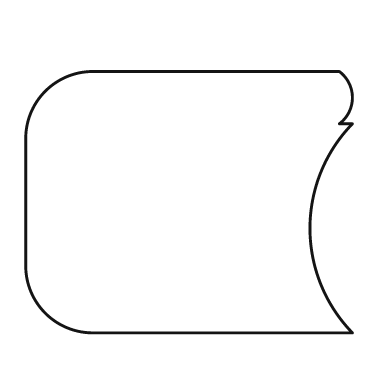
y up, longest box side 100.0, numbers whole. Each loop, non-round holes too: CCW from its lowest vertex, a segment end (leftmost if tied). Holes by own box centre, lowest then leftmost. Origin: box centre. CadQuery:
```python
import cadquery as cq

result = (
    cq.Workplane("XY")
    .moveTo(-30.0, -40.0)
    .lineTo(50.0, -40.0)
    .threePointArc((37.0, -8.0), (50.0, 24.0))
    .lineTo(46.0, 24.0)
    .threePointArc((50.0, 32.0), (46.0, 40.0))
    .lineTo(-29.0, 40.0)
    .threePointArc((-44.0, 34.0), (-50.0, 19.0))
    .lineTo(-50.0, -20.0)
    .threePointArc((-44.0, -34.0), (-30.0, -40.0))
    .close()
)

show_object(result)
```